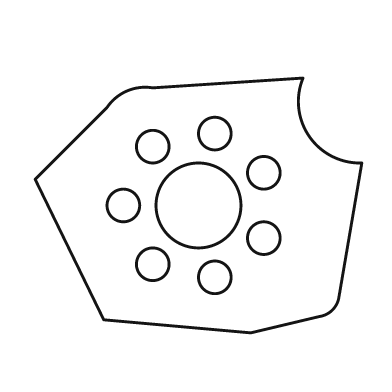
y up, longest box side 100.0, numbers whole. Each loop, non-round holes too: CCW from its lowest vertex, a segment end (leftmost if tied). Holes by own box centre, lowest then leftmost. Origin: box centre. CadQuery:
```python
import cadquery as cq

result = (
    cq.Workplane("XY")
    .moveTo(16.0, -39.0)
    .lineTo(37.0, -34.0)
    .threePointArc((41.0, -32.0), (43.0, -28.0))
    .lineTo(50.0, 13.0)
    .threePointArc((34.0, 21.0), (32.0, 39.0))
    .lineTo(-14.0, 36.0)
    .threePointArc((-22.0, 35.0), (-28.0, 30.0))
    .lineTo(-50.0, 8.0)
    .lineTo(-29.0, -35.0)
    .close()
    .moveTo(5.0, -22.0)
    .circle(5.0)
    .moveTo(-14.0, -18.0)
    .circle(5.0)
    .moveTo(20.0, -10.0)
    .circle(5.0)
    .moveTo(-23.0, 0.0)
    .circle(5.0)
    .moveTo(0.0, 0.0)
    .circle(13.0)
    .moveTo(20.0, 10.0)
    .circle(5.0)
    .moveTo(-14.0, 18.0)
    .circle(5.0)
    .moveTo(5.0, 22.0)
    .circle(5.0)
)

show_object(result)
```